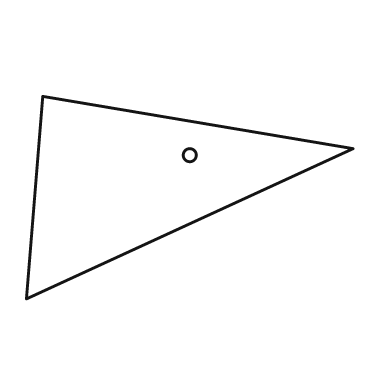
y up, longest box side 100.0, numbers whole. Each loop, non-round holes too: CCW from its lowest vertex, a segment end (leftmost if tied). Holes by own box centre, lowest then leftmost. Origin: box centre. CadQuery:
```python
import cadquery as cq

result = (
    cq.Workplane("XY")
    .moveTo(-50.0, -31.0)
    .lineTo(50.0, 15.0)
    .lineTo(-45.0, 31.0)
    .close()
    .moveTo(0.0, 13.0)
    .circle(2.0)
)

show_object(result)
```